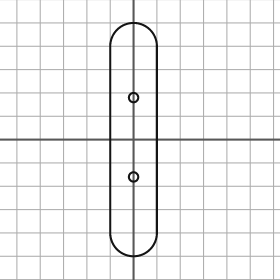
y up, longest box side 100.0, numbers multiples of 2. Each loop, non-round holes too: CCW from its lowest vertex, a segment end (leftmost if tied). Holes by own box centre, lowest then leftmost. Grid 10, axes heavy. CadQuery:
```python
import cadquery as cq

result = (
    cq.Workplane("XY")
    .moveTo(-10.0, -40.0)
    .threePointArc((0.0, -50.0), (10.0, -40.0))
    .lineTo(10.0, 40.0)
    .threePointArc((0.0, 50.0), (-10.0, 40.0))
    .close()
    .moveTo(0.0, -16.0)
    .circle(2.0)
    .moveTo(0.0, 18.0)
    .circle(2.0)
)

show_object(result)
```